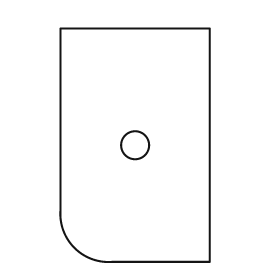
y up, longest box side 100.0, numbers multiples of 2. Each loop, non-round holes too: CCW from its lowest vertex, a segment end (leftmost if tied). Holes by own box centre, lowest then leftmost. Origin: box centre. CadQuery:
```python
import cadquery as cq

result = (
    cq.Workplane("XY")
    .moveTo(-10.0, -50.0)
    .lineTo(32.0, -50.0)
    .lineTo(32.0, 50.0)
    .lineTo(-32.0, 50.0)
    .lineTo(-32.0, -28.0)
    .threePointArc((-26.0, -44.0), (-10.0, -50.0))
    .close()
    .moveTo(0.0, 0.0)
    .circle(6.0)
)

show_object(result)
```